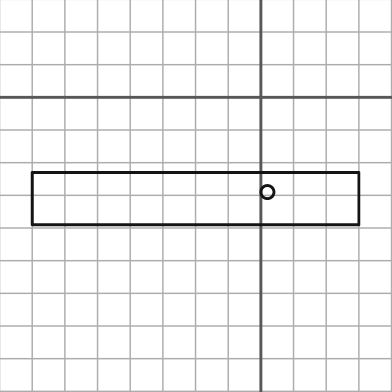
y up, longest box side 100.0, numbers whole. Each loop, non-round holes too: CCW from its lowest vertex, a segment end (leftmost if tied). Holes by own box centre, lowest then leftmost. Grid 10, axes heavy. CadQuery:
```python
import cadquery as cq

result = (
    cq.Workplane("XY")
    .moveTo(-70.0, -39.0)
    .lineTo(30.0, -39.0)
    .lineTo(30.0, -23.0)
    .lineTo(-70.0, -23.0)
    .close()
    .moveTo(2.0, -29.0)
    .circle(2.0)
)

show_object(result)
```